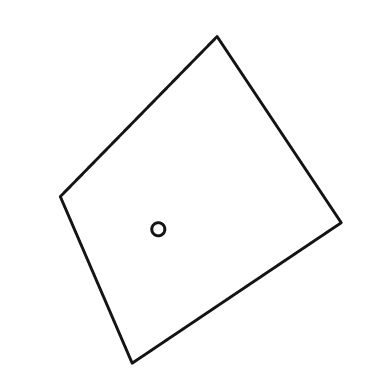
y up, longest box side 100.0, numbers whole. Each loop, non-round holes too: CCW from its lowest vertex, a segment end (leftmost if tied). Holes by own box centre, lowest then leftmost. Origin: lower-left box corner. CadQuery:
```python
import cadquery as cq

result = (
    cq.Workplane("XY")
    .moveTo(22.0, 0.0)
    .lineTo(86.0, 43.0)
    .lineTo(48.0, 100.0)
    .lineTo(0.0, 51.0)
    .close()
    .moveTo(30.0, 41.0)
    .circle(2.0)
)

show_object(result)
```